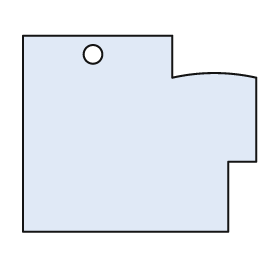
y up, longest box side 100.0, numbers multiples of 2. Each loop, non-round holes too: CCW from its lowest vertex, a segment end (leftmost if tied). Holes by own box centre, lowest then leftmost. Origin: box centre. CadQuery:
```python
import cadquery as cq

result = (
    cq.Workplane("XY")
    .moveTo(-50.0, -42.0)
    .lineTo(38.0, -42.0)
    .lineTo(38.0, -12.0)
    .lineTo(50.0, -12.0)
    .lineTo(50.0, 24.0)
    .threePointArc((32.0, 26.0), (14.0, 24.0))
    .lineTo(14.0, 42.0)
    .lineTo(-50.0, 42.0)
    .close()
    .moveTo(-20.0, 34.0)
    .circle(4.0)
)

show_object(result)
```